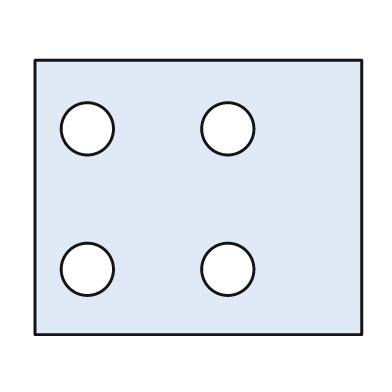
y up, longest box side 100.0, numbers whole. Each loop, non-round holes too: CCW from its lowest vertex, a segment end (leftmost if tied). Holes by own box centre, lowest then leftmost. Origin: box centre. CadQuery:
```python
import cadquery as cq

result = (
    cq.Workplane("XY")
    .moveTo(-50.0, -42.0)
    .lineTo(50.0, -42.0)
    .lineTo(50.0, 42.0)
    .lineTo(-50.0, 42.0)
    .close()
    .moveTo(-34.0, -22.0)
    .circle(8.0)
    .moveTo(9.0, -22.0)
    .circle(8.0)
    .moveTo(-34.0, 21.0)
    .circle(8.0)
    .moveTo(9.0, 21.0)
    .circle(8.0)
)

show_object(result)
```